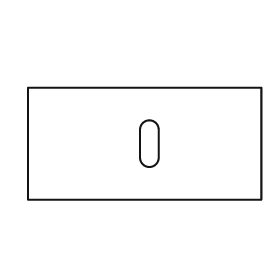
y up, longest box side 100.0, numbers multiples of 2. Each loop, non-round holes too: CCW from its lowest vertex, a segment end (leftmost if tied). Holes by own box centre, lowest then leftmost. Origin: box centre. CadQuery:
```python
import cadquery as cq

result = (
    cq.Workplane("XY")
    .moveTo(-50.0, -24.0)
    .lineTo(50.0, -24.0)
    .lineTo(50.0, 24.0)
    .lineTo(-50.0, 24.0)
    .close()
    .moveTo(-2.0, -6.0)
    .threePointArc((2.0, -10.0), (6.0, -6.0))
    .lineTo(6.0, 6.0)
    .threePointArc((2.0, 10.0), (-2.0, 6.0))
    .close()
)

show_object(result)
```